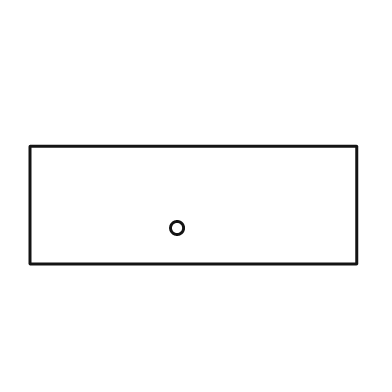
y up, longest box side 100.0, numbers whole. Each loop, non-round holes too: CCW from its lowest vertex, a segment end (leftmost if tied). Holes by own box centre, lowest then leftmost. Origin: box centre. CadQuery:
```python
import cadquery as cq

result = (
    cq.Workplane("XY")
    .moveTo(-50.0, -18.0)
    .lineTo(50.0, -18.0)
    .lineTo(50.0, 18.0)
    .lineTo(-50.0, 18.0)
    .close()
    .moveTo(-5.0, -7.0)
    .circle(2.0)
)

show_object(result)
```